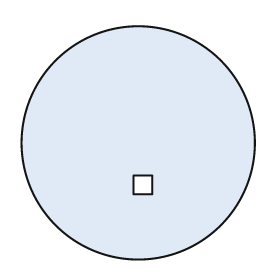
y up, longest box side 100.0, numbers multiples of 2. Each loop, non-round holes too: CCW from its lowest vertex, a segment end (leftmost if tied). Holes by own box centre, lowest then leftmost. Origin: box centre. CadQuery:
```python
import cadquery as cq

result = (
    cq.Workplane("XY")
    .moveTo(0.0, 0.0)
    .circle(50.0)
    .moveTo(-2.0, -22.0)
    .lineTo(6.0, -22.0)
    .lineTo(6.0, -14.0)
    .lineTo(-2.0, -14.0)
    .close()
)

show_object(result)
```